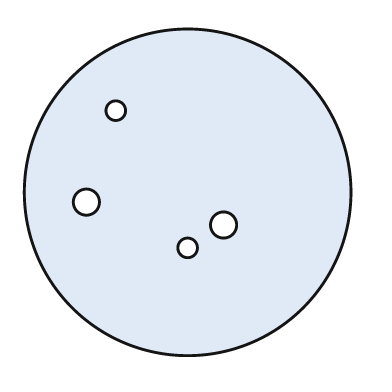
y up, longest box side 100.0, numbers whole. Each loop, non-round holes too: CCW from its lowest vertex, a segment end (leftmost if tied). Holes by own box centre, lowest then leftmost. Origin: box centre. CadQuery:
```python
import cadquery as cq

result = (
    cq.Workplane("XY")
    .moveTo(0.0, 0.0)
    .circle(50.0)
    .moveTo(0.0, -17.0)
    .circle(3.0)
    .moveTo(11.0, -10.0)
    .circle(4.0)
    .moveTo(-31.0, -3.0)
    .circle(4.0)
    .moveTo(-22.0, 25.0)
    .circle(3.0)
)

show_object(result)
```